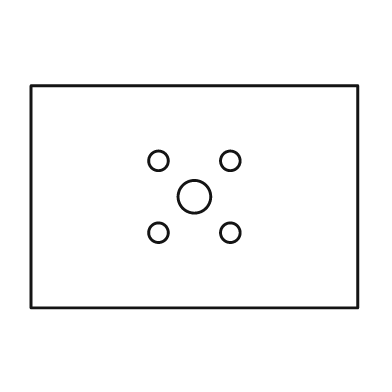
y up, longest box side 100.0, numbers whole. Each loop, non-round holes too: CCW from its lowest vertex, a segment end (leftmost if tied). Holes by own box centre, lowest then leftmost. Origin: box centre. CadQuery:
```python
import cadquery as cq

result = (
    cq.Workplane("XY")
    .moveTo(-50.0, -34.0)
    .lineTo(50.0, -34.0)
    .lineTo(50.0, 34.0)
    .lineTo(-50.0, 34.0)
    .close()
    .moveTo(-11.0, -11.0)
    .circle(3.0)
    .moveTo(11.0, -11.0)
    .circle(3.0)
    .moveTo(0.0, 0.0)
    .circle(5.0)
    .moveTo(-11.0, 11.0)
    .circle(3.0)
    .moveTo(11.0, 11.0)
    .circle(3.0)
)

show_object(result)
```